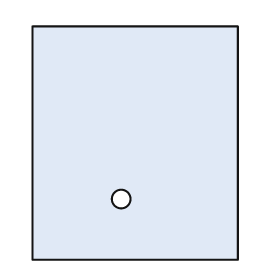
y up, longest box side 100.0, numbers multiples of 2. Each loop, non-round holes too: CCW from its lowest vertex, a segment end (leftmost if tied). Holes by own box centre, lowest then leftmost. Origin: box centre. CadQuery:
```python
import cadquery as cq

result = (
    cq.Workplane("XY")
    .moveTo(-44.0, -50.0)
    .lineTo(44.0, -50.0)
    .lineTo(44.0, 50.0)
    .lineTo(-44.0, 50.0)
    .close()
    .moveTo(-6.0, -24.0)
    .circle(4.0)
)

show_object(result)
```